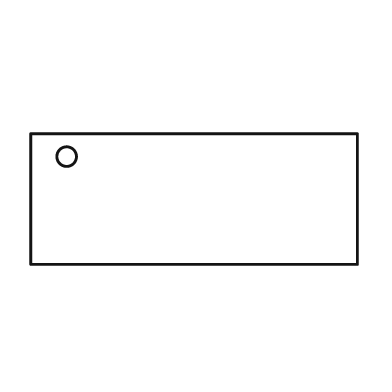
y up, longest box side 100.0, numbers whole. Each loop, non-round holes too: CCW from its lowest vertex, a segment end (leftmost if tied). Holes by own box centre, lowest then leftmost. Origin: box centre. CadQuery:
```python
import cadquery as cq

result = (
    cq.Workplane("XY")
    .moveTo(-50.0, -20.0)
    .lineTo(50.0, -20.0)
    .lineTo(50.0, 20.0)
    .lineTo(-50.0, 20.0)
    .close()
    .moveTo(-39.0, 13.0)
    .circle(3.0)
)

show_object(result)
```